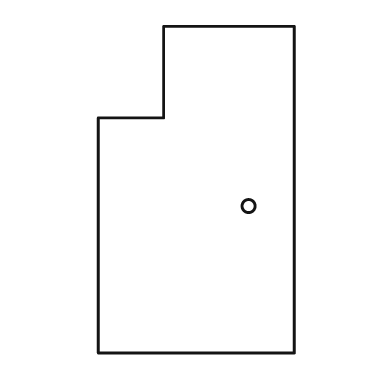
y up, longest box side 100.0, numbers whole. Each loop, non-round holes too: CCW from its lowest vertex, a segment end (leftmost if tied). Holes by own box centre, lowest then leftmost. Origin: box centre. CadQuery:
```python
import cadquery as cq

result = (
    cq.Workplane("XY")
    .moveTo(-30.0, -50.0)
    .lineTo(30.0, -50.0)
    .lineTo(30.0, 50.0)
    .lineTo(-10.0, 50.0)
    .lineTo(-10.0, 22.0)
    .lineTo(-30.0, 22.0)
    .close()
    .moveTo(16.0, -5.0)
    .circle(2.0)
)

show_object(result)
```